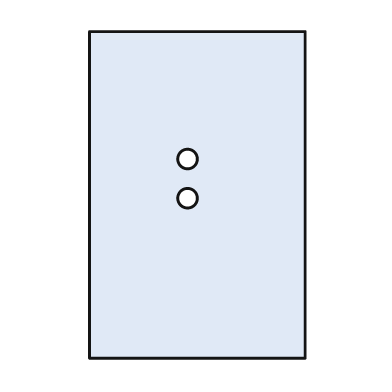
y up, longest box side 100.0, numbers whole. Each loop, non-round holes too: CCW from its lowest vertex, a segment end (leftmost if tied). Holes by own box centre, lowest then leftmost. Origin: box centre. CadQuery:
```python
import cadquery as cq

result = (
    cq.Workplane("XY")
    .moveTo(-33.0, -50.0)
    .lineTo(33.0, -50.0)
    .lineTo(33.0, 50.0)
    .lineTo(-33.0, 50.0)
    .close()
    .moveTo(-3.0, -1.0)
    .circle(3.0)
    .moveTo(-3.0, 11.0)
    .circle(3.0)
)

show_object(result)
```